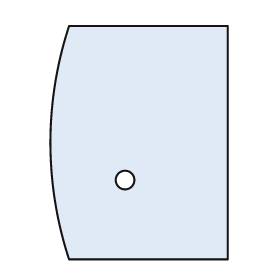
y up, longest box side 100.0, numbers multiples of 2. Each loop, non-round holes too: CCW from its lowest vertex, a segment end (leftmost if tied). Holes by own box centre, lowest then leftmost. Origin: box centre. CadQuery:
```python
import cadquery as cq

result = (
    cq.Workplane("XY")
    .moveTo(-30.0, -50.0)
    .lineTo(38.0, -50.0)
    .lineTo(38.0, 50.0)
    .lineTo(-30.0, 50.0)
    .threePointArc((-38.0, 0.0), (-30.0, -50.0))
    .close()
    .moveTo(-6.0, -16.0)
    .circle(4.0)
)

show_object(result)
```